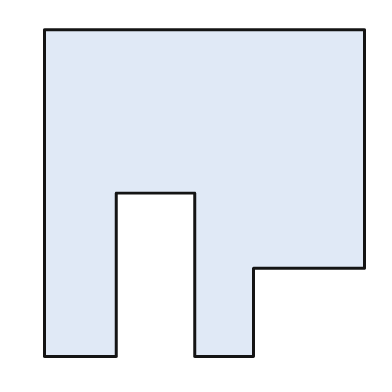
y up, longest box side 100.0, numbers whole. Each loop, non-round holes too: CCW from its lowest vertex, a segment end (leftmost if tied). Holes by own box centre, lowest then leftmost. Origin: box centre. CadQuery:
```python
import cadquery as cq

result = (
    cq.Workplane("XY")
    .moveTo(-49.0, -50.0)
    .lineTo(-27.0, -50.0)
    .lineTo(-27.0, 0.0)
    .lineTo(-3.0, 0.0)
    .lineTo(-3.0, -50.0)
    .lineTo(15.0, -50.0)
    .lineTo(15.0, -23.0)
    .lineTo(49.0, -23.0)
    .lineTo(49.0, 50.0)
    .lineTo(-49.0, 50.0)
    .close()
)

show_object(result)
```